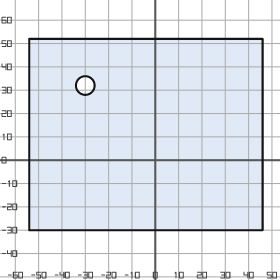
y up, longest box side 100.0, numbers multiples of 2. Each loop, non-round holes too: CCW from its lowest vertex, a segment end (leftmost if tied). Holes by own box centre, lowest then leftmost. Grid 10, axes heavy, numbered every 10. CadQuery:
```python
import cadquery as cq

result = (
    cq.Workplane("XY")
    .moveTo(-54.0, -30.0)
    .lineTo(46.0, -30.0)
    .lineTo(46.0, 52.0)
    .lineTo(-54.0, 52.0)
    .close()
    .moveTo(-30.0, 32.0)
    .circle(4.0)
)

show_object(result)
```